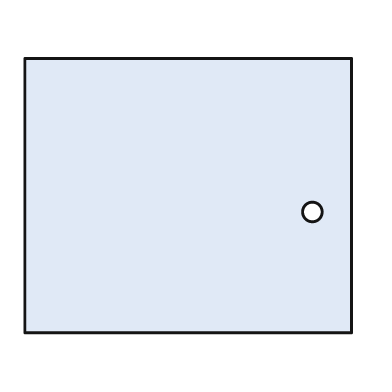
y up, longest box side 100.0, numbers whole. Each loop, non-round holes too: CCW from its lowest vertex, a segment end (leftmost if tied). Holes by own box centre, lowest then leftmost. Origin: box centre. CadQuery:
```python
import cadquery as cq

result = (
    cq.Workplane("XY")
    .moveTo(-50.0, -42.0)
    .lineTo(50.0, -42.0)
    .lineTo(50.0, 42.0)
    .lineTo(-50.0, 42.0)
    .close()
    .moveTo(38.0, -5.0)
    .circle(3.0)
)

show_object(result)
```